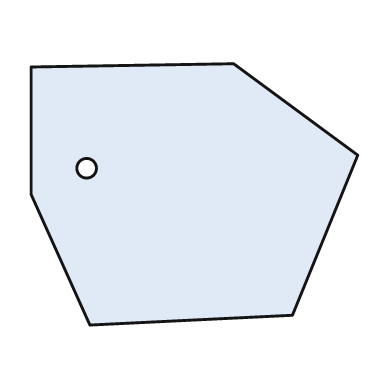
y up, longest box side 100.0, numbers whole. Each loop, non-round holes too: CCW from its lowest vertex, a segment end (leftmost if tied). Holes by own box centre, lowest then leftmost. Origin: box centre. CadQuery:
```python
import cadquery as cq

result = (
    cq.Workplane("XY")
    .moveTo(-32.0, -40.0)
    .lineTo(30.0, -37.0)
    .lineTo(50.0, 12.0)
    .lineTo(12.0, 40.0)
    .lineTo(-50.0, 39.0)
    .lineTo(-50.0, 0.0)
    .close()
    .moveTo(-33.0, 8.0)
    .circle(3.0)
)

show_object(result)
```